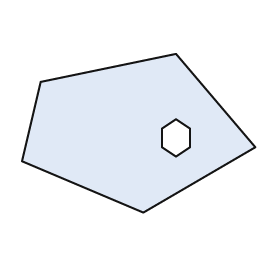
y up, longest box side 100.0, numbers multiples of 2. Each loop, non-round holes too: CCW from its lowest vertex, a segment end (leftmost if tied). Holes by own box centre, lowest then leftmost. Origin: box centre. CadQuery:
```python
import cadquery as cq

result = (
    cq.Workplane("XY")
    .moveTo(2.0, -34.0)
    .lineTo(50.0, -6.0)
    .lineTo(16.0, 34.0)
    .lineTo(-42.0, 22.0)
    .lineTo(-50.0, -12.0)
    .close()
    .moveTo(16.0, -10.0)
    .lineTo(22.0, -6.0)
    .lineTo(22.0, 2.0)
    .lineTo(16.0, 6.0)
    .lineTo(10.0, 2.0)
    .lineTo(10.0, -6.0)
    .close()
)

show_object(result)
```